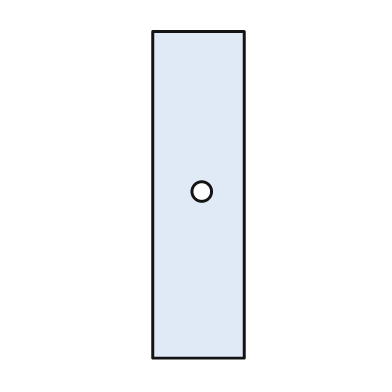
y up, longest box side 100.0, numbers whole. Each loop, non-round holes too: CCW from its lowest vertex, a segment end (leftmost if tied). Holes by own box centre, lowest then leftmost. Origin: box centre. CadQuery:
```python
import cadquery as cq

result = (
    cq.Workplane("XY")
    .moveTo(-14.0, -50.0)
    .lineTo(14.0, -50.0)
    .lineTo(14.0, 50.0)
    .lineTo(-14.0, 50.0)
    .close()
    .moveTo(1.0, 1.0)
    .circle(3.0)
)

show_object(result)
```